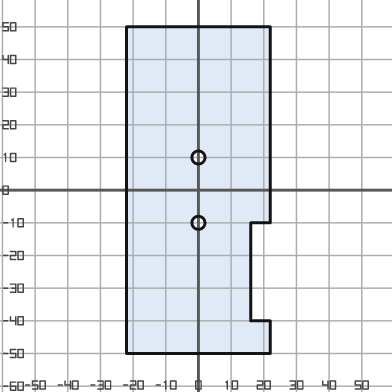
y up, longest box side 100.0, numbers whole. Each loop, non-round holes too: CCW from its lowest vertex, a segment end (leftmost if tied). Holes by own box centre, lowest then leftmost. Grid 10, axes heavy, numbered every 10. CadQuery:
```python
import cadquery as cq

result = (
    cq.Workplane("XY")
    .moveTo(-22.0, -50.0)
    .lineTo(22.0, -50.0)
    .lineTo(22.0, -40.0)
    .lineTo(16.0, -40.0)
    .lineTo(16.0, -10.0)
    .lineTo(22.0, -10.0)
    .lineTo(22.0, 50.0)
    .lineTo(-22.0, 50.0)
    .close()
    .moveTo(0.0, -10.0)
    .circle(2.0)
    .moveTo(0.0, 10.0)
    .circle(2.0)
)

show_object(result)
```